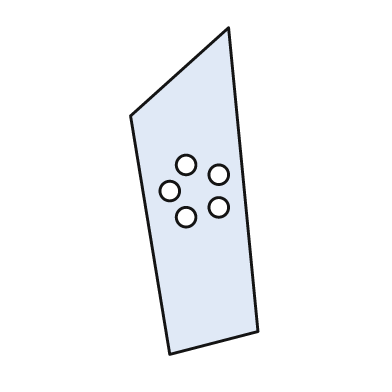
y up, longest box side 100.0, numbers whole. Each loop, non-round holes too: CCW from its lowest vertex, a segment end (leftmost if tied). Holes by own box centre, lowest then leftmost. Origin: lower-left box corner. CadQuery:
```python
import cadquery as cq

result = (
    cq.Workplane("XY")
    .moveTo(12.0, 0.0)
    .lineTo(39.0, 7.0)
    .lineTo(30.0, 100.0)
    .lineTo(0.0, 73.0)
    .close()
    .moveTo(17.0, 42.0)
    .circle(3.0)
    .moveTo(27.0, 45.0)
    .circle(3.0)
    .moveTo(12.0, 50.0)
    .circle(3.0)
    .moveTo(27.0, 55.0)
    .circle(3.0)
    .moveTo(17.0, 58.0)
    .circle(3.0)
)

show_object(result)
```